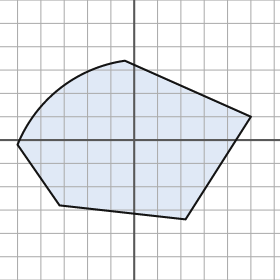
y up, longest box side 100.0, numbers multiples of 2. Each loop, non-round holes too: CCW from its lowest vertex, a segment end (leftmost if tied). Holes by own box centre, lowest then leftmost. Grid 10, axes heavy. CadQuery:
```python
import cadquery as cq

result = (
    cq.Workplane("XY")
    .moveTo(22.0, -34.0)
    .lineTo(50.0, 10.0)
    .lineTo(-4.0, 34.0)
    .threePointArc((-32.0, 22.0), (-50.0, -2.0))
    .lineTo(-32.0, -28.0)
    .close()
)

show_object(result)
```